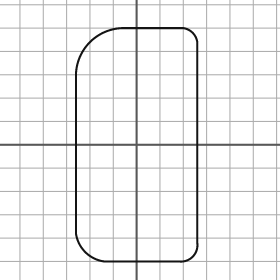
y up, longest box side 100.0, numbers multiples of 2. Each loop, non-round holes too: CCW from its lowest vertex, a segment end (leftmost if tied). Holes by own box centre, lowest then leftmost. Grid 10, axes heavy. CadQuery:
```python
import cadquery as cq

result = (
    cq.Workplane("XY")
    .moveTo(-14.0, -50.0)
    .lineTo(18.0, -50.0)
    .threePointArc((24.0, -48.0), (26.0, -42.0))
    .lineTo(26.0, 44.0)
    .threePointArc((24.0, 48.0), (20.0, 50.0))
    .lineTo(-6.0, 50.0)
    .threePointArc((-20.0, 44.0), (-26.0, 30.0))
    .lineTo(-26.0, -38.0)
    .threePointArc((-22.0, -46.0), (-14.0, -50.0))
    .close()
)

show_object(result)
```